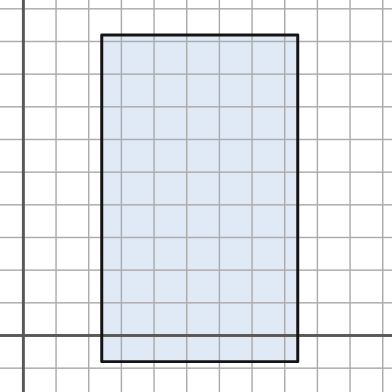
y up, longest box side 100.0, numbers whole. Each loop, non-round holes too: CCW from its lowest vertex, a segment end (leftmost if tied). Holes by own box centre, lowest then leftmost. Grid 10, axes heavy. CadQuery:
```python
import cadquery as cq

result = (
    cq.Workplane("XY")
    .moveTo(24.0, -8.0)
    .lineTo(84.0, -8.0)
    .lineTo(84.0, 92.0)
    .lineTo(24.0, 92.0)
    .close()
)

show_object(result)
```